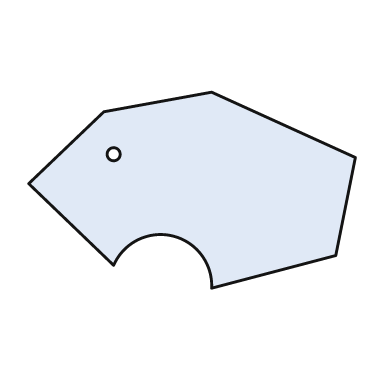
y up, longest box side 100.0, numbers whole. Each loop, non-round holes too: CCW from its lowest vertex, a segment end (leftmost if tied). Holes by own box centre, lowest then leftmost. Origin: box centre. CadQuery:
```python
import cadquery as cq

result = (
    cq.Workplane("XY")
    .moveTo(6.0, -30.0)
    .lineTo(44.0, -20.0)
    .lineTo(50.0, 10.0)
    .lineTo(6.0, 30.0)
    .lineTo(-27.0, 24.0)
    .lineTo(-50.0, 2.0)
    .lineTo(-24.0, -23.0)
    .threePointArc((-6.0, -14.0), (6.0, -30.0))
    .close()
    .moveTo(-24.0, 11.0)
    .circle(2.0)
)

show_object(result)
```